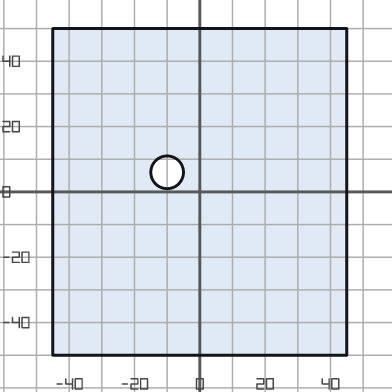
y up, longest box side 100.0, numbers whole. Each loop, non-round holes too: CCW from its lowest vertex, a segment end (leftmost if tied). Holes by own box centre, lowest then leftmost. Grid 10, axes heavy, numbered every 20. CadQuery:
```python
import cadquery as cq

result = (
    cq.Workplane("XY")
    .moveTo(-45.0, -50.0)
    .lineTo(45.0, -50.0)
    .lineTo(45.0, 50.0)
    .lineTo(-45.0, 50.0)
    .close()
    .moveTo(-10.0, 6.0)
    .circle(5.0)
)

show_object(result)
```